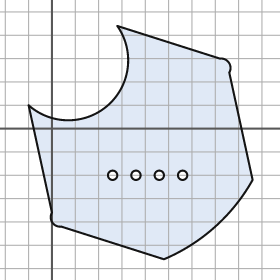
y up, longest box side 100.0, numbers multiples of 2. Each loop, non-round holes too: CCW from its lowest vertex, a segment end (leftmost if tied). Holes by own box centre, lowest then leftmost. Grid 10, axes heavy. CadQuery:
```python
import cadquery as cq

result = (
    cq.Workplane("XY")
    .moveTo(48.0, -56.0)
    .threePointArc((70.0, -42.0), (86.0, -22.0))
    .lineTo(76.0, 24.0)
    .threePointArc((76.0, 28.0), (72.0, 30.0))
    .lineTo(28.0, 44.0)
    .threePointArc((24.0, 10.0), (-10.0, 10.0))
    .lineTo(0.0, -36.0)
    .threePointArc((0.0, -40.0), (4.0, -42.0))
    .close()
    .moveTo(26.0, -20.0)
    .circle(2.0)
    .moveTo(36.0, -20.0)
    .circle(2.0)
    .moveTo(46.0, -20.0)
    .circle(2.0)
    .moveTo(56.0, -20.0)
    .circle(2.0)
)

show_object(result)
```